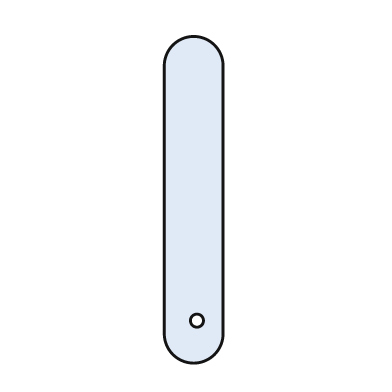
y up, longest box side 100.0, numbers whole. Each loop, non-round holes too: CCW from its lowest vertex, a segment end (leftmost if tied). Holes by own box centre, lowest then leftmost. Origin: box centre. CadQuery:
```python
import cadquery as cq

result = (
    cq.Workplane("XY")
    .moveTo(-9.0, -41.0)
    .threePointArc((0.0, -50.0), (9.0, -41.0))
    .lineTo(9.0, 41.0)
    .threePointArc((0.0, 50.0), (-9.0, 41.0))
    .close()
    .moveTo(1.0, -37.0)
    .circle(2.0)
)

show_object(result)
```